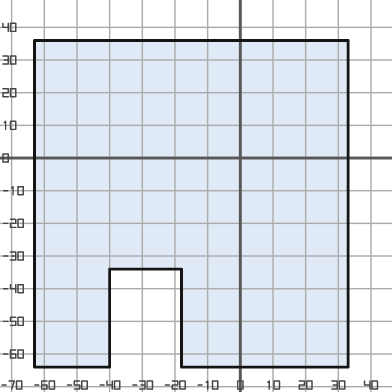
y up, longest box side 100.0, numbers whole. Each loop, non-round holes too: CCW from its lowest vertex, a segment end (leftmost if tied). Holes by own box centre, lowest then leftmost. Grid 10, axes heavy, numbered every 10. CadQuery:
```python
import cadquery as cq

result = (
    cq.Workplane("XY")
    .moveTo(-63.0, -64.0)
    .lineTo(-40.0, -64.0)
    .lineTo(-40.0, -34.0)
    .lineTo(-18.0, -34.0)
    .lineTo(-18.0, -64.0)
    .lineTo(33.0, -64.0)
    .lineTo(33.0, 36.0)
    .lineTo(-63.0, 36.0)
    .close()
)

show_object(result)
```